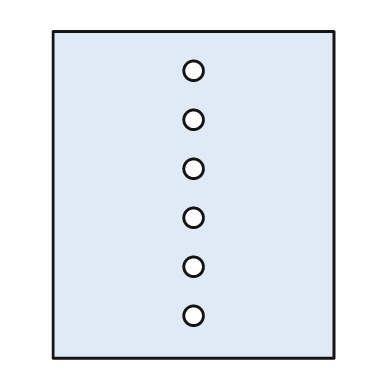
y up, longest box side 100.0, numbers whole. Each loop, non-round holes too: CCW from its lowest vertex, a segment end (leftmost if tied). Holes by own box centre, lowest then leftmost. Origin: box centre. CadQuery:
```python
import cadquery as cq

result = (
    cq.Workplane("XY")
    .moveTo(-43.0, -50.0)
    .lineTo(43.0, -50.0)
    .lineTo(43.0, 50.0)
    .lineTo(-43.0, 50.0)
    .close()
    .moveTo(0.0, -37.0)
    .circle(3.0)
    .moveTo(0.0, -22.0)
    .circle(3.0)
    .moveTo(0.0, -7.0)
    .circle(3.0)
    .moveTo(0.0, 8.0)
    .circle(3.0)
    .moveTo(0.0, 23.0)
    .circle(3.0)
    .moveTo(0.0, 38.0)
    .circle(3.0)
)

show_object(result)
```